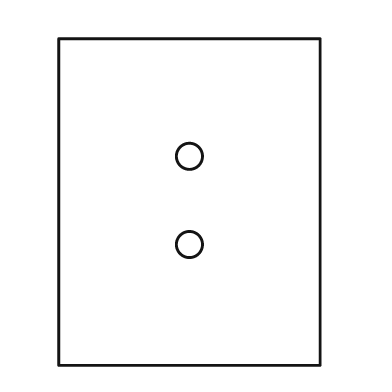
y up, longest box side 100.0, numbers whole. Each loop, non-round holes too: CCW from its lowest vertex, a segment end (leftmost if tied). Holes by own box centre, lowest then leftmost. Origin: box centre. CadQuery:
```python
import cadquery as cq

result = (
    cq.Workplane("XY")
    .moveTo(-40.0, -50.0)
    .lineTo(40.0, -50.0)
    .lineTo(40.0, 50.0)
    .lineTo(-40.0, 50.0)
    .close()
    .moveTo(0.0, -13.0)
    .circle(4.0)
    .moveTo(0.0, 14.0)
    .circle(4.0)
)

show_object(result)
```